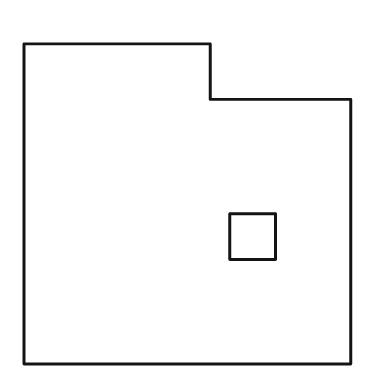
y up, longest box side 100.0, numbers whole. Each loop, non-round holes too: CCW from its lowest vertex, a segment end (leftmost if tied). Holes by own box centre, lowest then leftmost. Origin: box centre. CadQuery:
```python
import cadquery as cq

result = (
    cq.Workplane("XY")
    .moveTo(-50.0, -49.0)
    .lineTo(50.0, -49.0)
    .lineTo(50.0, 32.0)
    .lineTo(7.0, 32.0)
    .lineTo(7.0, 49.0)
    .lineTo(-50.0, 49.0)
    .close()
    .moveTo(13.0, -17.0)
    .lineTo(27.0, -17.0)
    .lineTo(27.0, -3.0)
    .lineTo(13.0, -3.0)
    .close()
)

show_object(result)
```